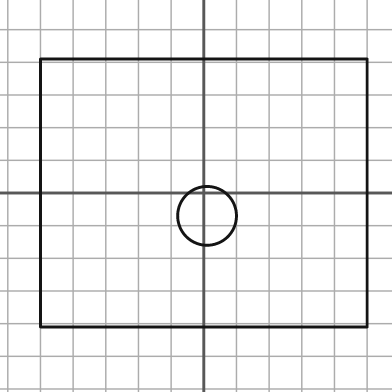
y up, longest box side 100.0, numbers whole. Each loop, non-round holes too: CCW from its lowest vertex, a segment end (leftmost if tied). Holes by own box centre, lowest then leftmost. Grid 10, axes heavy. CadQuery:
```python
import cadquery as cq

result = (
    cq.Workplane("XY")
    .moveTo(-50.0, -41.0)
    .lineTo(50.0, -41.0)
    .lineTo(50.0, 41.0)
    .lineTo(-50.0, 41.0)
    .close()
    .moveTo(1.0, -7.0)
    .circle(9.0)
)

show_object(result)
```